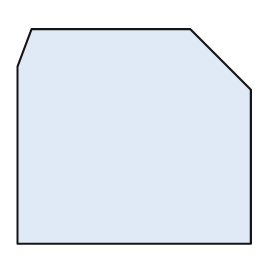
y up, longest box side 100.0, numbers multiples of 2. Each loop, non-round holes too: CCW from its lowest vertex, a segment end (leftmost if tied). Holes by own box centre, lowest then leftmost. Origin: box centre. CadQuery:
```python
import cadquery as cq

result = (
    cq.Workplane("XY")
    .moveTo(-50.0, -46.0)
    .lineTo(50.0, -46.0)
    .lineTo(50.0, 20.0)
    .lineTo(24.0, 46.0)
    .lineTo(-44.0, 46.0)
    .lineTo(-50.0, 30.0)
    .close()
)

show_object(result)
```